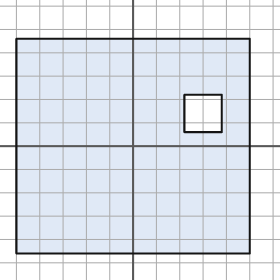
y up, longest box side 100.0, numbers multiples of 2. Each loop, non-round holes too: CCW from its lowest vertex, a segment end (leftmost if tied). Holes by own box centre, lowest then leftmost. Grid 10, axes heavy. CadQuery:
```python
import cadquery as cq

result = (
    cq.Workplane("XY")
    .moveTo(-50.0, -46.0)
    .lineTo(50.0, -46.0)
    .lineTo(50.0, 46.0)
    .lineTo(-50.0, 46.0)
    .close()
    .moveTo(22.0, 6.0)
    .lineTo(38.0, 6.0)
    .lineTo(38.0, 22.0)
    .lineTo(22.0, 22.0)
    .close()
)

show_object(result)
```